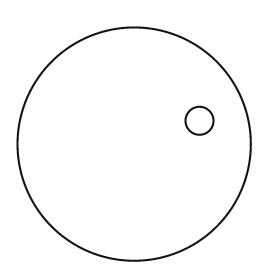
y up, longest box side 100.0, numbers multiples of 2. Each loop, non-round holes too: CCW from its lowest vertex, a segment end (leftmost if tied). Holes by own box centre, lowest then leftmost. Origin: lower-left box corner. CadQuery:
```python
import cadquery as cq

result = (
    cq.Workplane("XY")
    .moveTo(50.0, 50.0)
    .circle(50.0)
    .moveTo(78.0, 60.0)
    .circle(6.0)
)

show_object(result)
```